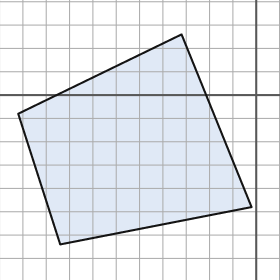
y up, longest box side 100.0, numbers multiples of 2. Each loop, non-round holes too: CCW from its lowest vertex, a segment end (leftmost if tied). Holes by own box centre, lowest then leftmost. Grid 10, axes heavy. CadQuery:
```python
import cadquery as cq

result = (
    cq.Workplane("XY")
    .moveTo(-84.0, -64.0)
    .lineTo(-2.0, -48.0)
    .lineTo(-32.0, 26.0)
    .lineTo(-102.0, -8.0)
    .close()
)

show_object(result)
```